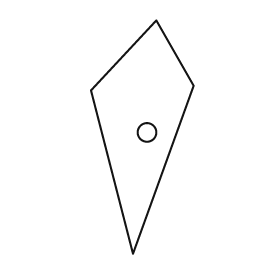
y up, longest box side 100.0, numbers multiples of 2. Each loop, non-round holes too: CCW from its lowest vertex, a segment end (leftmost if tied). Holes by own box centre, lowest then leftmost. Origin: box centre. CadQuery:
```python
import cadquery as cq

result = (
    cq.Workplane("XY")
    .moveTo(-4.0, -50.0)
    .lineTo(22.0, 22.0)
    .lineTo(6.0, 50.0)
    .lineTo(-22.0, 20.0)
    .close()
    .moveTo(2.0, 2.0)
    .circle(4.0)
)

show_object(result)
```